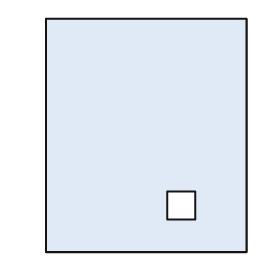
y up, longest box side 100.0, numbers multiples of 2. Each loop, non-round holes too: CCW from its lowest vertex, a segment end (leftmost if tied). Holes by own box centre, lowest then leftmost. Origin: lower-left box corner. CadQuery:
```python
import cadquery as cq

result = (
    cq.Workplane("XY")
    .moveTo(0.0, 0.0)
    .lineTo(86.0, 0.0)
    .lineTo(86.0, 100.0)
    .lineTo(0.0, 100.0)
    .close()
    .moveTo(52.0, 14.0)
    .lineTo(64.0, 14.0)
    .lineTo(64.0, 26.0)
    .lineTo(52.0, 26.0)
    .close()
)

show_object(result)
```